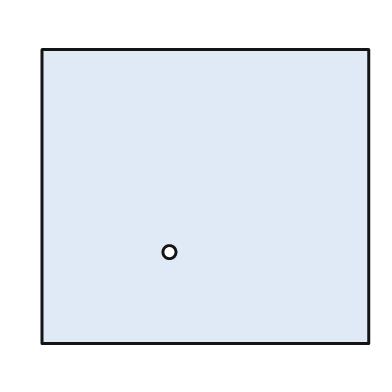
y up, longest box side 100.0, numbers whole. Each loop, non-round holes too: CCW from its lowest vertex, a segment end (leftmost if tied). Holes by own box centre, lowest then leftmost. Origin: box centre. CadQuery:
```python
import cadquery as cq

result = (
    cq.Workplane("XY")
    .moveTo(-50.0, -45.0)
    .lineTo(50.0, -45.0)
    .lineTo(50.0, 45.0)
    .lineTo(-50.0, 45.0)
    .close()
    .moveTo(-11.0, -17.0)
    .circle(2.0)
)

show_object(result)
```